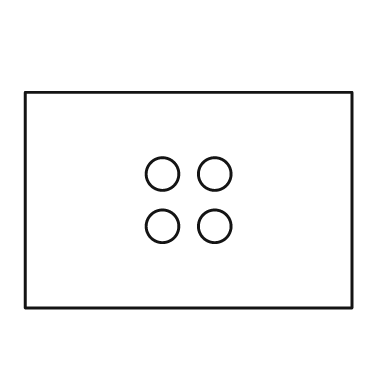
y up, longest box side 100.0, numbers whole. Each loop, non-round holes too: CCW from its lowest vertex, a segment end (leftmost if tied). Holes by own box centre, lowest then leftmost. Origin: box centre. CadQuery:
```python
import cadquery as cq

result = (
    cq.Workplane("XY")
    .moveTo(-50.0, -33.0)
    .lineTo(50.0, -33.0)
    .lineTo(50.0, 33.0)
    .lineTo(-50.0, 33.0)
    .close()
    .moveTo(-8.0, -8.0)
    .circle(5.0)
    .moveTo(8.0, -8.0)
    .circle(5.0)
    .moveTo(-8.0, 8.0)
    .circle(5.0)
    .moveTo(8.0, 8.0)
    .circle(5.0)
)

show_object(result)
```